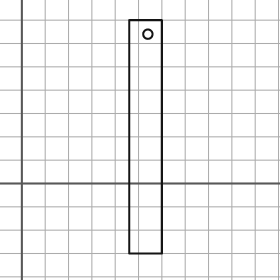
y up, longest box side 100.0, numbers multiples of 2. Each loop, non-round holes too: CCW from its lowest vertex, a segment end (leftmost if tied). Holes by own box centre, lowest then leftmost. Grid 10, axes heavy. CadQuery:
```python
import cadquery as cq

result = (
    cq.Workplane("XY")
    .moveTo(46.0, -30.0)
    .lineTo(60.0, -30.0)
    .lineTo(60.0, 70.0)
    .lineTo(46.0, 70.0)
    .close()
    .moveTo(54.0, 64.0)
    .circle(2.0)
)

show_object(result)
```